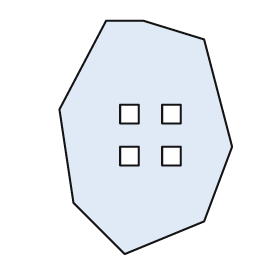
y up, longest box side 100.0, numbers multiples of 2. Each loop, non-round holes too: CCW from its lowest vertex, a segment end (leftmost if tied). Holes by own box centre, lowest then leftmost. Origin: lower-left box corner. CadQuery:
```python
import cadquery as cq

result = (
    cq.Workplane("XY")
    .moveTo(28.0, 0.0)
    .lineTo(62.0, 14.0)
    .lineTo(74.0, 46.0)
    .lineTo(62.0, 92.0)
    .lineTo(36.0, 100.0)
    .lineTo(20.0, 100.0)
    .lineTo(0.0, 62.0)
    .lineTo(6.0, 22.0)
    .close()
    .moveTo(26.0, 38.0)
    .lineTo(34.0, 38.0)
    .lineTo(34.0, 46.0)
    .lineTo(26.0, 46.0)
    .close()
    .moveTo(44.0, 38.0)
    .lineTo(52.0, 38.0)
    .lineTo(52.0, 46.0)
    .lineTo(44.0, 46.0)
    .close()
    .moveTo(26.0, 56.0)
    .lineTo(34.0, 56.0)
    .lineTo(34.0, 64.0)
    .lineTo(26.0, 64.0)
    .close()
    .moveTo(44.0, 56.0)
    .lineTo(52.0, 56.0)
    .lineTo(52.0, 64.0)
    .lineTo(44.0, 64.0)
    .close()
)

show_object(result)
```